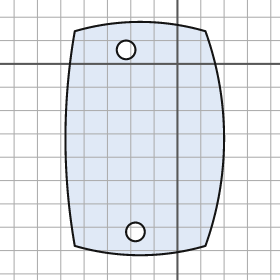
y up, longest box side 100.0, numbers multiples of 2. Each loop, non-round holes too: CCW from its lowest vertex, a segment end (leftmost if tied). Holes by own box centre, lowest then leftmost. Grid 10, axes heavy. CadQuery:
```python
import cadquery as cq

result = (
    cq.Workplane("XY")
    .moveTo(-44.0, -78.0)
    .threePointArc((-16.0, -82.0), (12.0, -78.0))
    .threePointArc((20.0, -32.0), (12.0, 14.0))
    .threePointArc((-16.0, 18.0), (-44.0, 14.0))
    .threePointArc((-48.0, -32.0), (-44.0, -78.0))
    .close()
    .moveTo(-18.0, -72.0)
    .circle(4.0)
    .moveTo(-22.0, 6.0)
    .circle(4.0)
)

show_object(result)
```